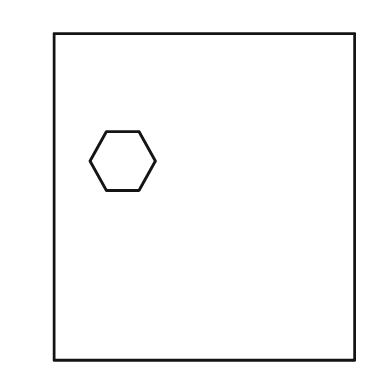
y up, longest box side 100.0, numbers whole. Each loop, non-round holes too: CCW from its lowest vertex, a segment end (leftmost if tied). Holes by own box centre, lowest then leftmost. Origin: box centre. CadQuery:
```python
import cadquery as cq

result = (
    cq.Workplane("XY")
    .moveTo(-46.0, -50.0)
    .lineTo(46.0, -50.0)
    .lineTo(46.0, 50.0)
    .lineTo(-46.0, 50.0)
    .close()
    .moveTo(-30.0, 2.0)
    .lineTo(-20.0, 2.0)
    .lineTo(-15.0, 11.0)
    .lineTo(-20.0, 20.0)
    .lineTo(-30.0, 20.0)
    .lineTo(-35.0, 11.0)
    .close()
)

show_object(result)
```